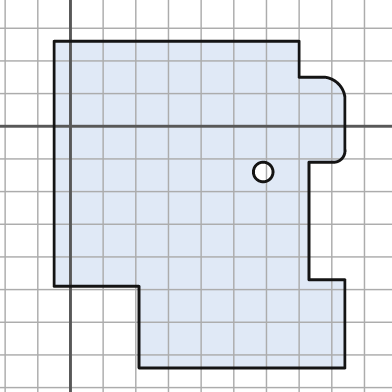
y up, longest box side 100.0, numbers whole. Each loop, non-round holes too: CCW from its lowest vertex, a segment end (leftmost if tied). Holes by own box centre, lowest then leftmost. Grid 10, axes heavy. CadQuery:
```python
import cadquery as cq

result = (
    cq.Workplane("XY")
    .moveTo(21.0, -74.0)
    .lineTo(84.0, -74.0)
    .lineTo(84.0, -47.0)
    .lineTo(73.0, -47.0)
    .lineTo(73.0, -11.0)
    .lineTo(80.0, -11.0)
    .threePointArc((83.0, -10.0), (84.0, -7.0))
    .lineTo(84.0, 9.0)
    .threePointArc((82.0, 13.0), (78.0, 15.0))
    .lineTo(70.0, 15.0)
    .lineTo(70.0, 26.0)
    .lineTo(-5.0, 26.0)
    .lineTo(-5.0, -49.0)
    .lineTo(21.0, -49.0)
    .close()
    .moveTo(59.0, -14.0)
    .circle(3.0)
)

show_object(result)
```